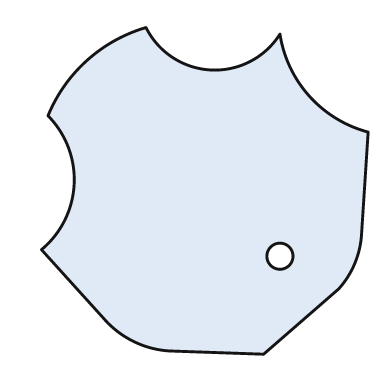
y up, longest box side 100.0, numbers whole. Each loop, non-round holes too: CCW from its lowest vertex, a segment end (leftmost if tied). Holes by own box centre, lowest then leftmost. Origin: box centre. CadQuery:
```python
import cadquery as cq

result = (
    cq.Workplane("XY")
    .moveTo(18.0, -50.0)
    .lineTo(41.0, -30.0)
    .threePointArc((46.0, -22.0), (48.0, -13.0))
    .lineTo(50.0, 18.0)
    .threePointArc((32.0, 29.0), (23.0, 48.0))
    .threePointArc((2.0, 37.0), (-18.0, 50.0))
    .threePointArc((-36.0, 40.0), (-48.0, 23.0))
    .threePointArc((-40.0, 2.0), (-50.0, -18.0))
    .lineTo(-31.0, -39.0)
    .threePointArc((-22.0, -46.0), (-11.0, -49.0))
    .close()
    .moveTo(23.0, -20.0)
    .circle(4.0)
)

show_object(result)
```